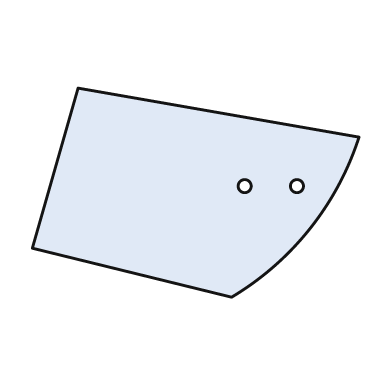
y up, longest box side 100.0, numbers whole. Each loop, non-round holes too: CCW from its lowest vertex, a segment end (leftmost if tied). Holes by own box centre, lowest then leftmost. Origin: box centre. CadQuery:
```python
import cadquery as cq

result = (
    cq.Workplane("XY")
    .moveTo(11.0, -32.0)
    .threePointArc((35.0, -11.0), (50.0, 17.0))
    .lineTo(-36.0, 32.0)
    .lineTo(-50.0, -17.0)
    .close()
    .moveTo(15.0, 2.0)
    .circle(2.0)
    .moveTo(31.0, 2.0)
    .circle(2.0)
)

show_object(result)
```